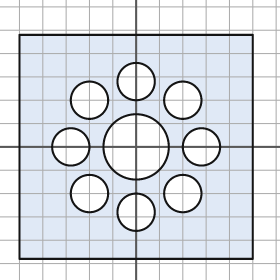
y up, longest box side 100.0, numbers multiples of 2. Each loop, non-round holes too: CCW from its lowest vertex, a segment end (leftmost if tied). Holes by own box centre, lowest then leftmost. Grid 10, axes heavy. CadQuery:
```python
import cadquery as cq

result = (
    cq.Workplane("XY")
    .moveTo(-50.0, -48.0)
    .lineTo(50.0, -48.0)
    .lineTo(50.0, 48.0)
    .lineTo(-50.0, 48.0)
    .close()
    .moveTo(0.0, -28.0)
    .circle(8.0)
    .moveTo(-20.0, -20.0)
    .circle(8.0)
    .moveTo(20.0, -20.0)
    .circle(8.0)
    .moveTo(-28.0, 0.0)
    .circle(8.0)
    .moveTo(0.0, 0.0)
    .circle(14.0)
    .moveTo(28.0, 0.0)
    .circle(8.0)
    .moveTo(-20.0, 20.0)
    .circle(8.0)
    .moveTo(20.0, 20.0)
    .circle(8.0)
    .moveTo(0.0, 28.0)
    .circle(8.0)
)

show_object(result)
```